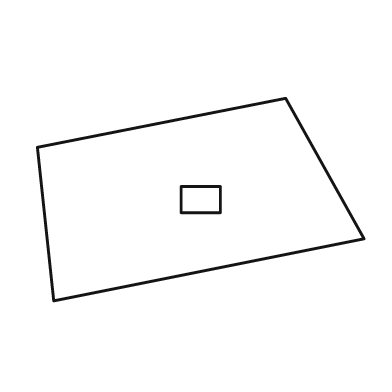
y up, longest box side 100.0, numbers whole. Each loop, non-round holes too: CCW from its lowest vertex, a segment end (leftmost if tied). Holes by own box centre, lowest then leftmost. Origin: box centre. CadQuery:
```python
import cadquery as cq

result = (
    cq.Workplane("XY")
    .moveTo(-45.0, -31.0)
    .lineTo(50.0, -12.0)
    .lineTo(26.0, 31.0)
    .lineTo(-50.0, 16.0)
    .close()
    .moveTo(-6.0, -4.0)
    .lineTo(6.0, -4.0)
    .lineTo(6.0, 4.0)
    .lineTo(-6.0, 4.0)
    .close()
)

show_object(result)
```